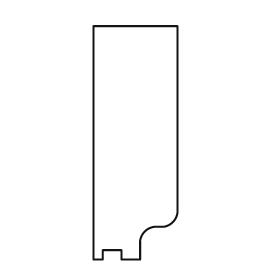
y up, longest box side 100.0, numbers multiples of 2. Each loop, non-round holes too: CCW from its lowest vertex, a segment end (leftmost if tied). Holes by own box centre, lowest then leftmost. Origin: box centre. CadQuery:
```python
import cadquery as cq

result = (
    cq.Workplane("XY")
    .moveTo(-18.0, -50.0)
    .lineTo(-14.0, -50.0)
    .lineTo(-14.0, -46.0)
    .lineTo(-6.0, -46.0)
    .lineTo(-6.0, -50.0)
    .lineTo(2.0, -50.0)
    .lineTo(2.0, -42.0)
    .threePointArc((4.0, -38.0), (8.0, -36.0))
    .lineTo(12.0, -36.0)
    .threePointArc((16.0, -34.0), (18.0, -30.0))
    .lineTo(18.0, 50.0)
    .lineTo(-18.0, 50.0)
    .close()
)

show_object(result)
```